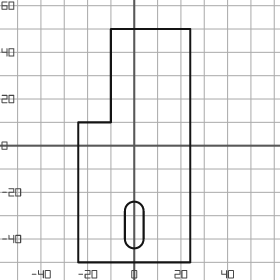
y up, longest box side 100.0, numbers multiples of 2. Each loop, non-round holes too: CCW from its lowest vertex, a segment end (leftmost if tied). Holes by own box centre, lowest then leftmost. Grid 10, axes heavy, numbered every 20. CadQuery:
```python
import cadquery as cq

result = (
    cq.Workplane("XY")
    .moveTo(-24.0, -50.0)
    .lineTo(24.0, -50.0)
    .lineTo(24.0, 50.0)
    .lineTo(-10.0, 50.0)
    .lineTo(-10.0, 10.0)
    .lineTo(-24.0, 10.0)
    .close()
    .moveTo(-4.0, -40.0)
    .threePointArc((0.0, -44.0), (4.0, -40.0))
    .lineTo(4.0, -28.0)
    .threePointArc((0.0, -24.0), (-4.0, -28.0))
    .close()
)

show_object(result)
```